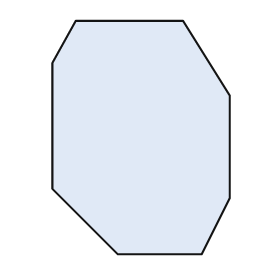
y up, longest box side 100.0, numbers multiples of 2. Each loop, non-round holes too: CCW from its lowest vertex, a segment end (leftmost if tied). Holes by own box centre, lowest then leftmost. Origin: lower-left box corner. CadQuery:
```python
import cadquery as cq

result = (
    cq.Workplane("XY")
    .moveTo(28.0, 0.0)
    .lineTo(64.0, 0.0)
    .lineTo(76.0, 24.0)
    .lineTo(76.0, 68.0)
    .lineTo(56.0, 100.0)
    .lineTo(10.0, 100.0)
    .lineTo(0.0, 82.0)
    .lineTo(0.0, 28.0)
    .close()
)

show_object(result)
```